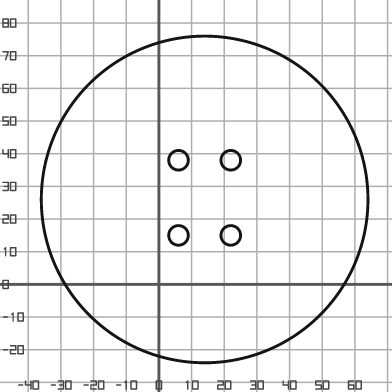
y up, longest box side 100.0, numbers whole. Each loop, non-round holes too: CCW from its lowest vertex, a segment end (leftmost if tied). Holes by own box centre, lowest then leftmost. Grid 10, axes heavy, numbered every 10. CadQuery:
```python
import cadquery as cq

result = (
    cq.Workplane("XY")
    .moveTo(14.0, 26.0)
    .circle(50.0)
    .moveTo(6.0, 15.0)
    .circle(3.0)
    .moveTo(22.0, 15.0)
    .circle(3.0)
    .moveTo(6.0, 38.0)
    .circle(3.0)
    .moveTo(22.0, 38.0)
    .circle(3.0)
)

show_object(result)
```